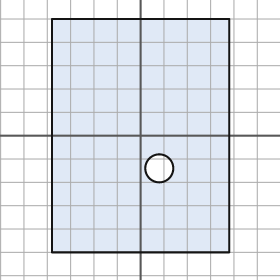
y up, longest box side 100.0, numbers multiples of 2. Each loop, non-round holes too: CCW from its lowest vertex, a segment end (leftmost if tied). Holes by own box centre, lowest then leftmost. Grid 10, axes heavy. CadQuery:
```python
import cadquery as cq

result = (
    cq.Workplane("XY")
    .moveTo(-38.0, -50.0)
    .lineTo(38.0, -50.0)
    .lineTo(38.0, 50.0)
    .lineTo(-38.0, 50.0)
    .close()
    .moveTo(8.0, -14.0)
    .circle(6.0)
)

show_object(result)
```